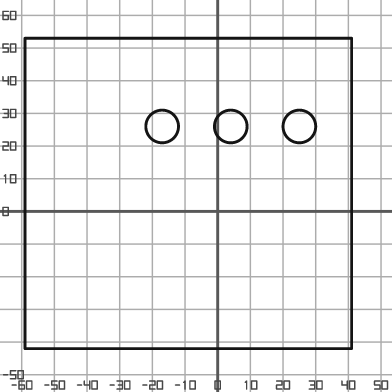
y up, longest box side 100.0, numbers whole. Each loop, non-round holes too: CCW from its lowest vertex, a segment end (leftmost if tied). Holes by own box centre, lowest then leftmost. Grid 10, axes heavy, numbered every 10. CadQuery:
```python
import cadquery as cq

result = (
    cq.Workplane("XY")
    .moveTo(-59.0, -42.0)
    .lineTo(41.0, -42.0)
    .lineTo(41.0, 53.0)
    .lineTo(-59.0, 53.0)
    .close()
    .moveTo(-17.0, 26.0)
    .circle(5.0)
    .moveTo(4.0, 26.0)
    .circle(5.0)
    .moveTo(25.0, 26.0)
    .circle(5.0)
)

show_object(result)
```